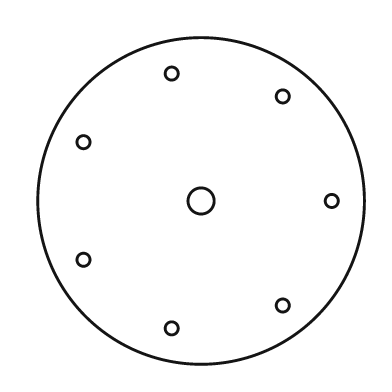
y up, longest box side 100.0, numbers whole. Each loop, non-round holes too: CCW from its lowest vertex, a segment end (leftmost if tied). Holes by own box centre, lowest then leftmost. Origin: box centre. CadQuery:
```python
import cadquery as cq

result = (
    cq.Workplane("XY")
    .moveTo(0.0, 0.0)
    .circle(50.0)
    .moveTo(-9.0, -39.0)
    .circle(2.0)
    .moveTo(25.0, -32.0)
    .circle(2.0)
    .moveTo(-36.0, -18.0)
    .circle(2.0)
    .moveTo(0.0, 0.0)
    .circle(4.0)
    .moveTo(40.0, 0.0)
    .circle(2.0)
    .moveTo(-36.0, 18.0)
    .circle(2.0)
    .moveTo(25.0, 32.0)
    .circle(2.0)
    .moveTo(-9.0, 39.0)
    .circle(2.0)
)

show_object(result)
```